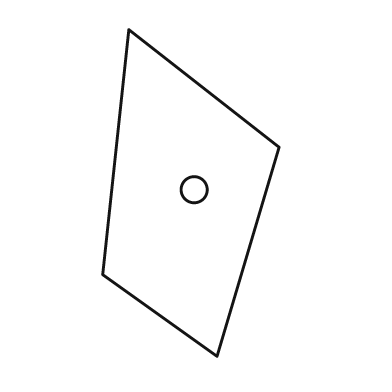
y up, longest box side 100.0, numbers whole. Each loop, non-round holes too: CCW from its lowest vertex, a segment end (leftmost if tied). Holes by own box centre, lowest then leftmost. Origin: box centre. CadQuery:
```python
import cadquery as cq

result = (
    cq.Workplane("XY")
    .moveTo(8.0, -50.0)
    .lineTo(27.0, 14.0)
    .lineTo(-19.0, 50.0)
    .lineTo(-27.0, -25.0)
    .close()
    .moveTo(1.0, 1.0)
    .circle(4.0)
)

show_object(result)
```